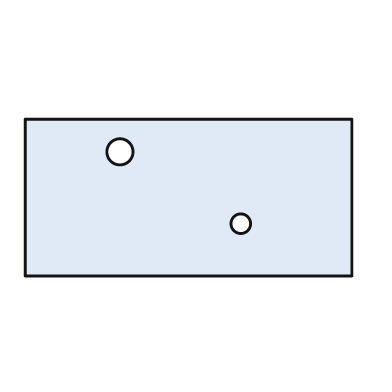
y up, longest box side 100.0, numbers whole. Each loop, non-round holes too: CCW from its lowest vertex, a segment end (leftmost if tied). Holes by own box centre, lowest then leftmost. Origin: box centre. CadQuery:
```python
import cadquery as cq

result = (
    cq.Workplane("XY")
    .moveTo(-50.0, -24.0)
    .lineTo(50.0, -24.0)
    .lineTo(50.0, 24.0)
    .lineTo(-50.0, 24.0)
    .close()
    .moveTo(16.0, -8.0)
    .circle(3.0)
    .moveTo(-21.0, 14.0)
    .circle(4.0)
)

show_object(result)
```